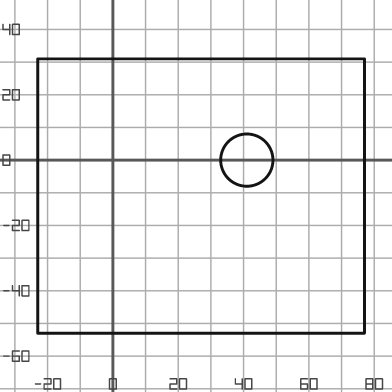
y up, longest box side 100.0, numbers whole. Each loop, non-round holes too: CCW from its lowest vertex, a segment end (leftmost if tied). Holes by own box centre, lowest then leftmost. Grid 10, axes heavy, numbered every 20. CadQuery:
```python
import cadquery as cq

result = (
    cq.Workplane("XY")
    .moveTo(-23.0, -53.0)
    .lineTo(77.0, -53.0)
    .lineTo(77.0, 31.0)
    .lineTo(-23.0, 31.0)
    .close()
    .moveTo(41.0, 0.0)
    .circle(8.0)
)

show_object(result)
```